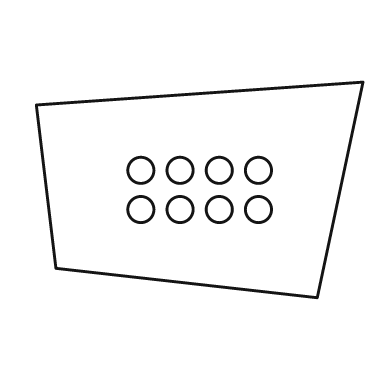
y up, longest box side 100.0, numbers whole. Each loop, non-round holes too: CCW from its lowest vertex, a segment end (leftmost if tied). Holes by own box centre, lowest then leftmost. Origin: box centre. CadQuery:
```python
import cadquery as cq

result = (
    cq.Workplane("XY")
    .moveTo(36.0, -33.0)
    .lineTo(50.0, 33.0)
    .lineTo(-50.0, 26.0)
    .lineTo(-44.0, -24.0)
    .close()
    .moveTo(-18.0, -6.0)
    .circle(4.0)
    .moveTo(-6.0, -6.0)
    .circle(4.0)
    .moveTo(6.0, -6.0)
    .circle(4.0)
    .moveTo(18.0, -6.0)
    .circle(4.0)
    .moveTo(-18.0, 6.0)
    .circle(4.0)
    .moveTo(-6.0, 6.0)
    .circle(4.0)
    .moveTo(6.0, 6.0)
    .circle(4.0)
    .moveTo(18.0, 6.0)
    .circle(4.0)
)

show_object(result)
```